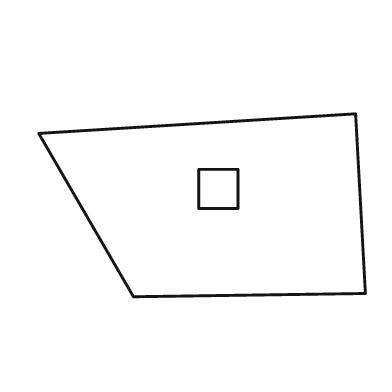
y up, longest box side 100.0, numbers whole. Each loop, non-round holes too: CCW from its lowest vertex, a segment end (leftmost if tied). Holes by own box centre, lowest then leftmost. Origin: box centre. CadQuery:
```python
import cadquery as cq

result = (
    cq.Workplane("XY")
    .moveTo(-21.0, -28.0)
    .lineTo(50.0, -27.0)
    .lineTo(47.0, 28.0)
    .lineTo(-50.0, 22.0)
    .close()
    .moveTo(-1.0, -1.0)
    .lineTo(11.0, -1.0)
    .lineTo(11.0, 11.0)
    .lineTo(-1.0, 11.0)
    .close()
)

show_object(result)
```